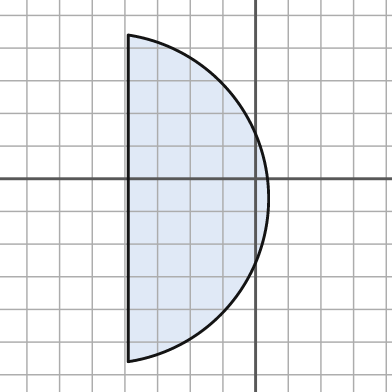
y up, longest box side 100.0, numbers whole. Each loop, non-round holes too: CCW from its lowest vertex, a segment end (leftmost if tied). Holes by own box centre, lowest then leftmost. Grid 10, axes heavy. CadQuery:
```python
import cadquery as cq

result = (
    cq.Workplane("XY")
    .moveTo(-39.0, -56.0)
    .threePointArc((4.0, -6.0), (-39.0, 44.0))
    .close()
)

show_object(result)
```